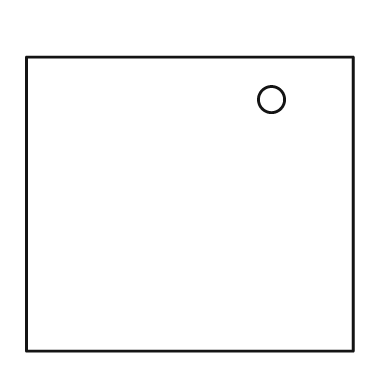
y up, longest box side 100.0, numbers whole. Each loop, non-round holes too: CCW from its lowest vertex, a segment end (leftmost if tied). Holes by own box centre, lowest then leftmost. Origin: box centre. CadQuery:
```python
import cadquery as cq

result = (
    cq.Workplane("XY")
    .moveTo(-50.0, -45.0)
    .lineTo(50.0, -45.0)
    .lineTo(50.0, 45.0)
    .lineTo(-50.0, 45.0)
    .close()
    .moveTo(25.0, 32.0)
    .circle(4.0)
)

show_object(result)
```